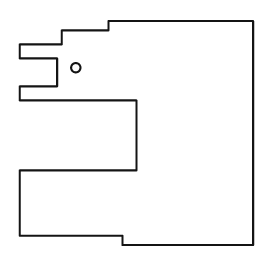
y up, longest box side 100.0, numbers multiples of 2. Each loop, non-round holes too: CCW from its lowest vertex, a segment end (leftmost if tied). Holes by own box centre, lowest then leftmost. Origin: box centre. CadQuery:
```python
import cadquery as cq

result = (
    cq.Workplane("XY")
    .moveTo(-6.0, -48.0)
    .lineTo(50.0, -48.0)
    .lineTo(50.0, 48.0)
    .lineTo(-12.0, 48.0)
    .lineTo(-12.0, 44.0)
    .lineTo(-32.0, 44.0)
    .lineTo(-32.0, 38.0)
    .lineTo(-50.0, 38.0)
    .lineTo(-50.0, 32.0)
    .lineTo(-34.0, 32.0)
    .lineTo(-34.0, 20.0)
    .lineTo(-50.0, 20.0)
    .lineTo(-50.0, 14.0)
    .lineTo(0.0, 14.0)
    .lineTo(0.0, -16.0)
    .lineTo(-50.0, -16.0)
    .lineTo(-50.0, -44.0)
    .lineTo(-6.0, -44.0)
    .close()
    .moveTo(-26.0, 28.0)
    .circle(2.0)
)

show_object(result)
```